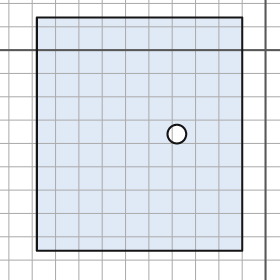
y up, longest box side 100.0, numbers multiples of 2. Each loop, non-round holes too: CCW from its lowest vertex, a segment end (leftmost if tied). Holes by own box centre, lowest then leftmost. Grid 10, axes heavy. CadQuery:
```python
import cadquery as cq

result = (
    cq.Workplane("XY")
    .moveTo(-98.0, -86.0)
    .lineTo(-10.0, -86.0)
    .lineTo(-10.0, 14.0)
    .lineTo(-98.0, 14.0)
    .close()
    .moveTo(-38.0, -36.0)
    .circle(4.0)
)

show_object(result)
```